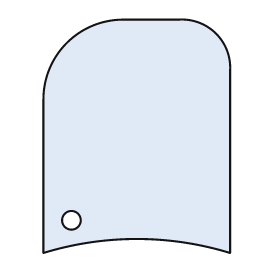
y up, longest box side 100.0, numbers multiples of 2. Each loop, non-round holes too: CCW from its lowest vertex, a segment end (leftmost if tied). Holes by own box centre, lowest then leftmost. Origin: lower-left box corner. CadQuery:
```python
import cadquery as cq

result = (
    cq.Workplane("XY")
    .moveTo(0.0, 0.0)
    .threePointArc((40.0, 6.0), (80.0, 0.0))
    .lineTo(80.0, 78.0)
    .threePointArc((74.0, 94.0), (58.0, 100.0))
    .lineTo(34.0, 100.0)
    .threePointArc((10.0, 90.0), (0.0, 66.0))
    .close()
    .moveTo(12.0, 14.0)
    .circle(4.0)
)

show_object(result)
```